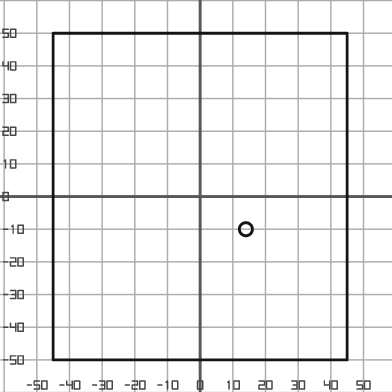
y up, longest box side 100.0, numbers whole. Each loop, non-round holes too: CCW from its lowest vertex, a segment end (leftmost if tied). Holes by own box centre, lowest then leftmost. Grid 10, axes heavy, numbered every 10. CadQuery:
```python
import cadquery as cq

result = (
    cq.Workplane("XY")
    .moveTo(-45.0, -50.0)
    .lineTo(45.0, -50.0)
    .lineTo(45.0, 50.0)
    .lineTo(-45.0, 50.0)
    .close()
    .moveTo(14.0, -10.0)
    .circle(2.0)
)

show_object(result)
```